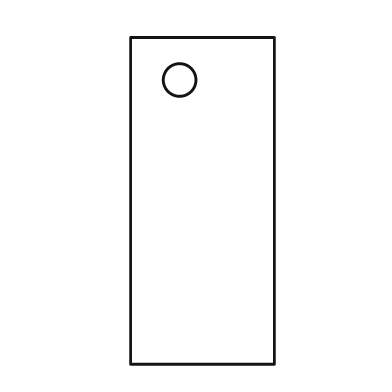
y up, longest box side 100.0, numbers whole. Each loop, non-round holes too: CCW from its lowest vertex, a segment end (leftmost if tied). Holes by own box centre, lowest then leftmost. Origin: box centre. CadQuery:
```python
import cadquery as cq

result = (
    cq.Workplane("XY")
    .moveTo(-22.0, -50.0)
    .lineTo(22.0, -50.0)
    .lineTo(22.0, 50.0)
    .lineTo(-22.0, 50.0)
    .close()
    .moveTo(-7.0, 37.0)
    .circle(5.0)
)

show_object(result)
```